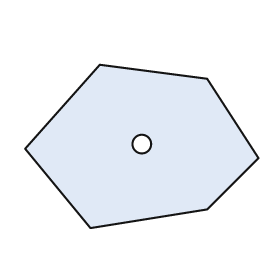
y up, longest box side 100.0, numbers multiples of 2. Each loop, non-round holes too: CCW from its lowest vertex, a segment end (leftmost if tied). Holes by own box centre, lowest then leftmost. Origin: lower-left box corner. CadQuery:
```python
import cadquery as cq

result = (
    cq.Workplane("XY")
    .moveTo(28.0, 0.0)
    .lineTo(78.0, 8.0)
    .lineTo(100.0, 30.0)
    .lineTo(78.0, 64.0)
    .lineTo(32.0, 70.0)
    .lineTo(0.0, 34.0)
    .close()
    .moveTo(50.0, 36.0)
    .circle(4.0)
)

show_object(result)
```